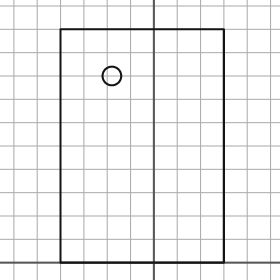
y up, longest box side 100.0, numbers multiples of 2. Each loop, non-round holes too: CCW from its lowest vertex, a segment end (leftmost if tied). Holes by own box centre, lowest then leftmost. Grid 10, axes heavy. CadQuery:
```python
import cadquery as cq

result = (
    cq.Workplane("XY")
    .moveTo(-40.0, 0.0)
    .lineTo(30.0, 0.0)
    .lineTo(30.0, 100.0)
    .lineTo(-40.0, 100.0)
    .close()
    .moveTo(-18.0, 80.0)
    .circle(4.0)
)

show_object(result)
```